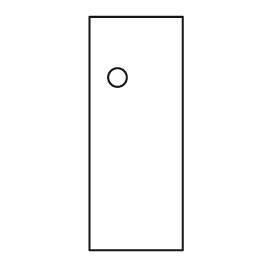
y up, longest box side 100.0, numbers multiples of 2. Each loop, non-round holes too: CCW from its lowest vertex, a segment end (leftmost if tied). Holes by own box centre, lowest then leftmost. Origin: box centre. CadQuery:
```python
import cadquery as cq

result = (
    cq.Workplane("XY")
    .moveTo(-20.0, -50.0)
    .lineTo(20.0, -50.0)
    .lineTo(20.0, 50.0)
    .lineTo(-20.0, 50.0)
    .close()
    .moveTo(-8.0, 24.0)
    .circle(4.0)
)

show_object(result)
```